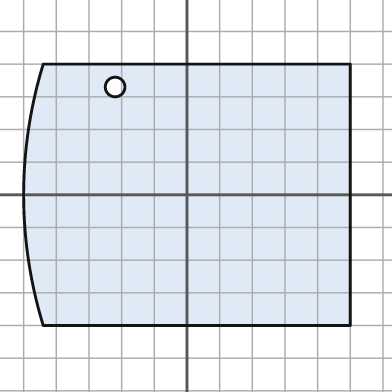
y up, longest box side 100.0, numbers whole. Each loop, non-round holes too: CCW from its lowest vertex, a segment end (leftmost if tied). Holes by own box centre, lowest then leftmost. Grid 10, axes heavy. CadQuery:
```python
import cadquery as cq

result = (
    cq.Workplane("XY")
    .moveTo(-44.0, -40.0)
    .lineTo(50.0, -40.0)
    .lineTo(50.0, 40.0)
    .lineTo(-44.0, 40.0)
    .threePointArc((-50.0, 0.0), (-44.0, -40.0))
    .close()
    .moveTo(-22.0, 33.0)
    .circle(3.0)
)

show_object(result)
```